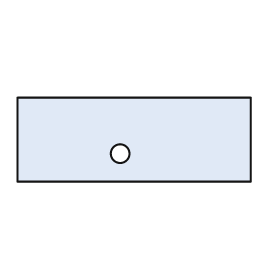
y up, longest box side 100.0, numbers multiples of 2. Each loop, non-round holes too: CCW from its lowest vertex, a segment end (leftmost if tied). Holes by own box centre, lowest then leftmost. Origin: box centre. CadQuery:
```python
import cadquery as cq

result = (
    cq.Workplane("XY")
    .moveTo(-50.0, -18.0)
    .lineTo(50.0, -18.0)
    .lineTo(50.0, 18.0)
    .lineTo(-50.0, 18.0)
    .close()
    .moveTo(-6.0, -6.0)
    .circle(4.0)
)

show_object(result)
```